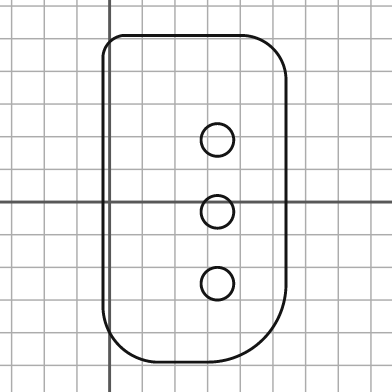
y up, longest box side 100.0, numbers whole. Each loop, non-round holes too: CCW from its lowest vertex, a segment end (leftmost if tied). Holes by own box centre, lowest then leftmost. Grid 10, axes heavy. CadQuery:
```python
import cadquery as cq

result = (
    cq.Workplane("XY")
    .moveTo(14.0, -49.0)
    .lineTo(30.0, -49.0)
    .threePointArc((47.0, -42.0), (54.0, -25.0))
    .lineTo(54.0, 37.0)
    .threePointArc((50.0, 47.0), (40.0, 51.0))
    .lineTo(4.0, 51.0)
    .threePointArc((0.0, 49.0), (-2.0, 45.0))
    .lineTo(-2.0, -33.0)
    .threePointArc((3.0, -44.0), (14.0, -49.0))
    .close()
    .moveTo(33.0, -25.0)
    .circle(5.0)
    .moveTo(33.0, -3.0)
    .circle(5.0)
    .moveTo(33.0, 19.0)
    .circle(5.0)
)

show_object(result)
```